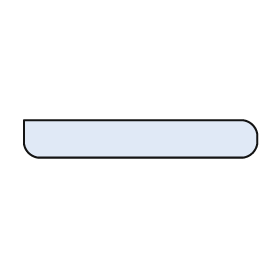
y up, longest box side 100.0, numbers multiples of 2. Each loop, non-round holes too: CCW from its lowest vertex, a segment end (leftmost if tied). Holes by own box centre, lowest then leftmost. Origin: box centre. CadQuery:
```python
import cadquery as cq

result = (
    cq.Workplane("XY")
    .moveTo(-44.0, -8.0)
    .lineTo(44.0, -8.0)
    .threePointArc((48.0, -6.0), (50.0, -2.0))
    .lineTo(50.0, 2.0)
    .threePointArc((48.0, 6.0), (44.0, 8.0))
    .lineTo(-50.0, 8.0)
    .lineTo(-50.0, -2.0)
    .threePointArc((-48.0, -6.0), (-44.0, -8.0))
    .close()
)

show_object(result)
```